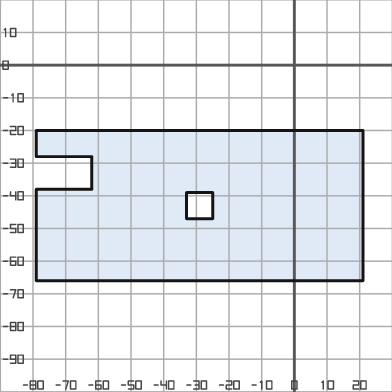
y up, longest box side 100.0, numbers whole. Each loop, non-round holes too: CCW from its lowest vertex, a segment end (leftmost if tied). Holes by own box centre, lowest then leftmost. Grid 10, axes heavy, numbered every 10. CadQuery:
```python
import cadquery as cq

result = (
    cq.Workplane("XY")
    .moveTo(-79.0, -66.0)
    .lineTo(21.0, -66.0)
    .lineTo(21.0, -20.0)
    .lineTo(-79.0, -20.0)
    .lineTo(-79.0, -28.0)
    .lineTo(-62.0, -28.0)
    .lineTo(-62.0, -38.0)
    .lineTo(-79.0, -38.0)
    .close()
    .moveTo(-33.0, -47.0)
    .lineTo(-25.0, -47.0)
    .lineTo(-25.0, -39.0)
    .lineTo(-33.0, -39.0)
    .close()
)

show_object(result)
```